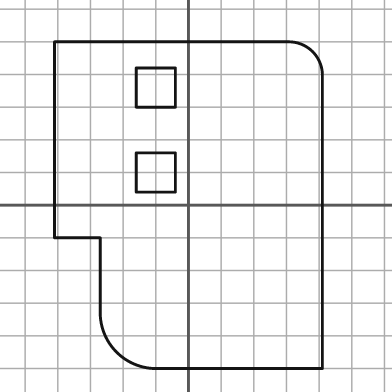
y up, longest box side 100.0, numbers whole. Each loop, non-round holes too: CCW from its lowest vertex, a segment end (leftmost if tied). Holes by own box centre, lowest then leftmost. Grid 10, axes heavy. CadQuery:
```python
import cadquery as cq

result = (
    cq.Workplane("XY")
    .moveTo(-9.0, -50.0)
    .lineTo(41.0, -50.0)
    .lineTo(41.0, 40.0)
    .threePointArc((38.0, 47.0), (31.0, 50.0))
    .lineTo(-41.0, 50.0)
    .lineTo(-41.0, -10.0)
    .lineTo(-27.0, -10.0)
    .lineTo(-27.0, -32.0)
    .threePointArc((-22.0, -45.0), (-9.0, -50.0))
    .close()
    .moveTo(-16.0, 4.0)
    .lineTo(-4.0, 4.0)
    .lineTo(-4.0, 16.0)
    .lineTo(-16.0, 16.0)
    .close()
    .moveTo(-16.0, 30.0)
    .lineTo(-4.0, 30.0)
    .lineTo(-4.0, 42.0)
    .lineTo(-16.0, 42.0)
    .close()
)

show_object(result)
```